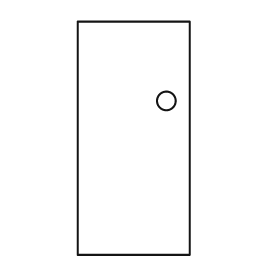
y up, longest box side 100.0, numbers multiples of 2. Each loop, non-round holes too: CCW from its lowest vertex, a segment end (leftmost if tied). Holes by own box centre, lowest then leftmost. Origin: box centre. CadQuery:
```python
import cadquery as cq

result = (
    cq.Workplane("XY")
    .moveTo(-24.0, -50.0)
    .lineTo(24.0, -50.0)
    .lineTo(24.0, 50.0)
    .lineTo(-24.0, 50.0)
    .close()
    .moveTo(14.0, 16.0)
    .circle(4.0)
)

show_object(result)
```